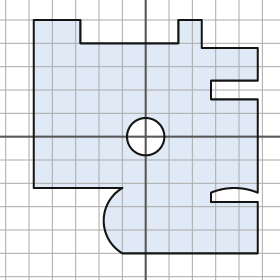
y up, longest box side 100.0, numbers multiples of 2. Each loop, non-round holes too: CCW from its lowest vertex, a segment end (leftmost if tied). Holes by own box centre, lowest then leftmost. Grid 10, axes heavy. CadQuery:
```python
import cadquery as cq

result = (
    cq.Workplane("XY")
    .moveTo(-10.0, -50.0)
    .lineTo(48.0, -50.0)
    .lineTo(48.0, -28.0)
    .lineTo(28.0, -28.0)
    .lineTo(28.0, -24.0)
    .threePointArc((38.0, -22.0), (48.0, -24.0))
    .lineTo(48.0, 16.0)
    .lineTo(28.0, 16.0)
    .lineTo(28.0, 24.0)
    .lineTo(48.0, 24.0)
    .lineTo(48.0, 38.0)
    .lineTo(24.0, 38.0)
    .lineTo(24.0, 50.0)
    .lineTo(14.0, 50.0)
    .lineTo(14.0, 40.0)
    .lineTo(-28.0, 40.0)
    .lineTo(-28.0, 50.0)
    .lineTo(-48.0, 50.0)
    .lineTo(-48.0, -22.0)
    .lineTo(-10.0, -22.0)
    .threePointArc((-18.0, -36.0), (-10.0, -50.0))
    .close()
    .moveTo(0.0, 0.0)
    .circle(8.0)
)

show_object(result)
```